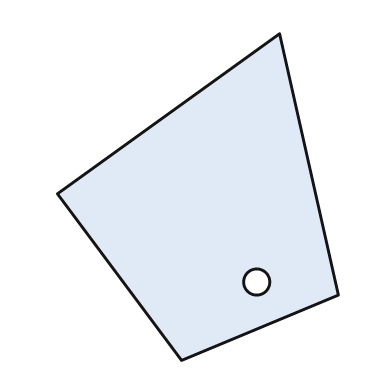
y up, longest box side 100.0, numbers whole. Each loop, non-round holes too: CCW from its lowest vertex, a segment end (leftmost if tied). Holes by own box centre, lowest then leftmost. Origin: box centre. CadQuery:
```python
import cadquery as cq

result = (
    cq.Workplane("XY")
    .moveTo(-5.0, -50.0)
    .lineTo(43.0, -30.0)
    .lineTo(25.0, 50.0)
    .lineTo(-43.0, 1.0)
    .close()
    .moveTo(18.0, -26.0)
    .circle(4.0)
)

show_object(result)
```